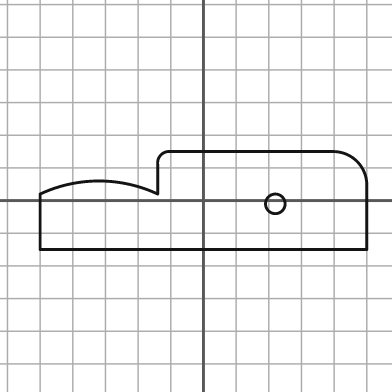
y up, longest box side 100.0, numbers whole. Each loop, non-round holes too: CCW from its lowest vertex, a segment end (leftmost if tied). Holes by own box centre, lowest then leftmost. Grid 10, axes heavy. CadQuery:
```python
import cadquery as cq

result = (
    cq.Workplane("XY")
    .moveTo(-50.0, -15.0)
    .lineTo(50.0, -15.0)
    .lineTo(50.0, 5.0)
    .threePointArc((47.0, 12.0), (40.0, 15.0))
    .lineTo(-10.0, 15.0)
    .threePointArc((-13.0, 14.0), (-14.0, 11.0))
    .lineTo(-14.0, 2.0)
    .threePointArc((-32.0, 6.0), (-50.0, 2.0))
    .close()
    .moveTo(22.0, -1.0)
    .circle(3.0)
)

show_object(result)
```